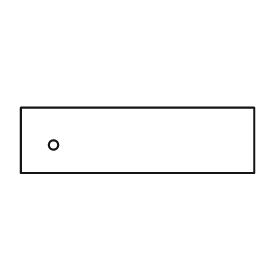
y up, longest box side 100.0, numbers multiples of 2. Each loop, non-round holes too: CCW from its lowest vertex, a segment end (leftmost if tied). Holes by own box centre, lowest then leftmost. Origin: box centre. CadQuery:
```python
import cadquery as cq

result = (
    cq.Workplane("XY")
    .moveTo(-50.0, -14.0)
    .lineTo(50.0, -14.0)
    .lineTo(50.0, 14.0)
    .lineTo(-50.0, 14.0)
    .close()
    .moveTo(-36.0, -2.0)
    .circle(2.0)
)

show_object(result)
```